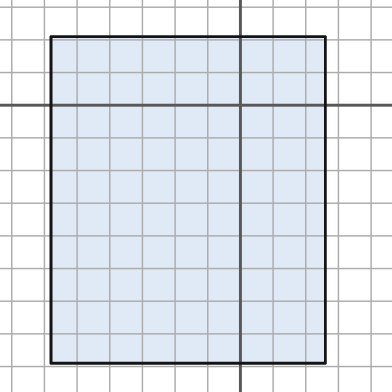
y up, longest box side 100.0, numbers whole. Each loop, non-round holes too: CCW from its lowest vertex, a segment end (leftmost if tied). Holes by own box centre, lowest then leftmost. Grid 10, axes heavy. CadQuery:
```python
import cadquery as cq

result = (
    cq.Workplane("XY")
    .moveTo(-58.0, -79.0)
    .lineTo(26.0, -79.0)
    .lineTo(26.0, 21.0)
    .lineTo(-58.0, 21.0)
    .close()
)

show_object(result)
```